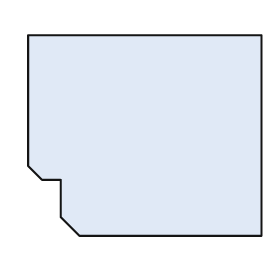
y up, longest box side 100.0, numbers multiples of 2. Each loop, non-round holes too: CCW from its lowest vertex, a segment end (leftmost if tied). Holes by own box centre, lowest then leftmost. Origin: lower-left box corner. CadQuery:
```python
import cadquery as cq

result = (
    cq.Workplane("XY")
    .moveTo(22.0, 0.0)
    .lineTo(100.0, 0.0)
    .lineTo(100.0, 86.0)
    .lineTo(0.0, 86.0)
    .lineTo(0.0, 30.0)
    .lineTo(6.0, 24.0)
    .lineTo(14.0, 24.0)
    .lineTo(14.0, 8.0)
    .close()
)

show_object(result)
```